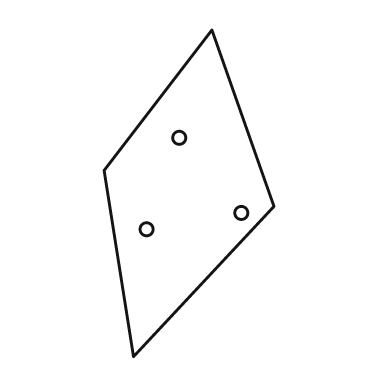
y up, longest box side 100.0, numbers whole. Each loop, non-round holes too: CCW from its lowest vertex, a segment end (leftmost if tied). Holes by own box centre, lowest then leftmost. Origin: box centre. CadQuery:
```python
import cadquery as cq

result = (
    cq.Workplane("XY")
    .moveTo(-17.0, -50.0)
    .lineTo(26.0, -4.0)
    .lineTo(7.0, 50.0)
    .lineTo(-26.0, 7.0)
    .close()
    .moveTo(-13.0, -11.0)
    .circle(2.0)
    .moveTo(16.0, -6.0)
    .circle(2.0)
    .moveTo(-3.0, 17.0)
    .circle(2.0)
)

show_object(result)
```